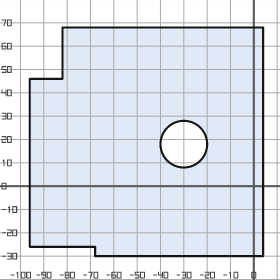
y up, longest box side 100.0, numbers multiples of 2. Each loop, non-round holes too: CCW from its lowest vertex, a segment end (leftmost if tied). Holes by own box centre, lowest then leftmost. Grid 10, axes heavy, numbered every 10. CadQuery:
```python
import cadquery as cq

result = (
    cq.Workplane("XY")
    .moveTo(-68.0, -30.0)
    .lineTo(4.0, -30.0)
    .lineTo(4.0, 68.0)
    .lineTo(-82.0, 68.0)
    .lineTo(-82.0, 46.0)
    .lineTo(-96.0, 46.0)
    .lineTo(-96.0, -26.0)
    .lineTo(-68.0, -26.0)
    .close()
    .moveTo(-30.0, 18.0)
    .circle(10.0)
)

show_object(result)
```